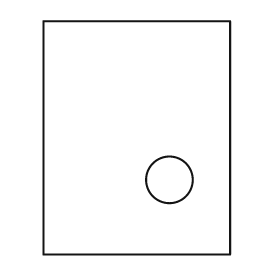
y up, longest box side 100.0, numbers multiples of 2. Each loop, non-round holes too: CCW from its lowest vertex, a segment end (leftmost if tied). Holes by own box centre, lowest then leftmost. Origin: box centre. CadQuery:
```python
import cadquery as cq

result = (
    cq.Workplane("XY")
    .moveTo(-40.0, -50.0)
    .lineTo(40.0, -50.0)
    .lineTo(40.0, 50.0)
    .lineTo(-40.0, 50.0)
    .close()
    .moveTo(14.0, -18.0)
    .circle(10.0)
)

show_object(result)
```